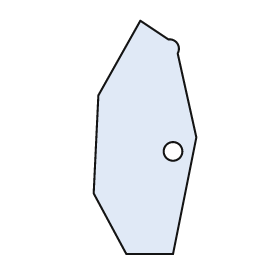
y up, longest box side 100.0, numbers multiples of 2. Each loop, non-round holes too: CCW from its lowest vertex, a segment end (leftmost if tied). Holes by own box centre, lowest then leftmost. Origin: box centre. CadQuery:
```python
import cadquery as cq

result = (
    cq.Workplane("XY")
    .moveTo(-8.0, -50.0)
    .lineTo(12.0, -50.0)
    .lineTo(22.0, 0.0)
    .lineTo(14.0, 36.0)
    .threePointArc((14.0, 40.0), (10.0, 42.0))
    .lineTo(-2.0, 50.0)
    .lineTo(-20.0, 18.0)
    .lineTo(-22.0, -24.0)
    .close()
    .moveTo(12.0, -6.0)
    .circle(4.0)
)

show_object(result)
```